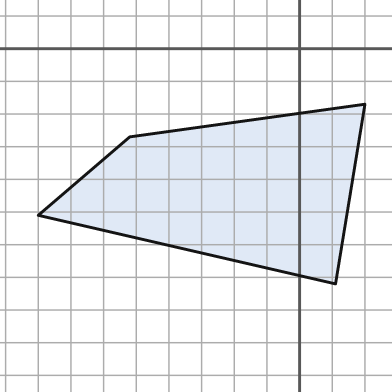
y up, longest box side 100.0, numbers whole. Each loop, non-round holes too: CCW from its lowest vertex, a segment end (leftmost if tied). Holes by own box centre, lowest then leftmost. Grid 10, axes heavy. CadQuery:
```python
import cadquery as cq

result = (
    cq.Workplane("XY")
    .moveTo(11.0, -72.0)
    .lineTo(20.0, -17.0)
    .lineTo(-52.0, -27.0)
    .lineTo(-80.0, -51.0)
    .close()
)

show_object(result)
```